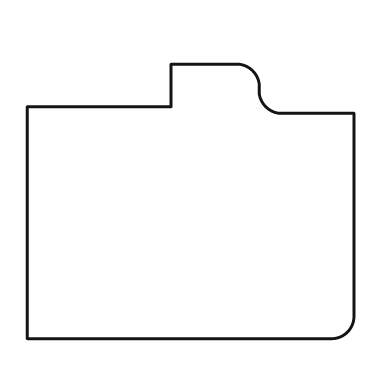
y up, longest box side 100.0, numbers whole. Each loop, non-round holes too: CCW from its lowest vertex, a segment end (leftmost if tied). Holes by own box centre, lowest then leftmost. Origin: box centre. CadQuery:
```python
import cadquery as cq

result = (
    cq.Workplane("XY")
    .moveTo(-50.0, -42.0)
    .lineTo(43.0, -42.0)
    .threePointArc((48.0, -40.0), (50.0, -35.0))
    .lineTo(50.0, 27.0)
    .lineTo(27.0, 27.0)
    .threePointArc((23.0, 29.0), (21.0, 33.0))
    .lineTo(21.0, 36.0)
    .threePointArc((19.0, 40.0), (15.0, 42.0))
    .lineTo(-6.0, 42.0)
    .lineTo(-6.0, 29.0)
    .lineTo(-50.0, 29.0)
    .close()
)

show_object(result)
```